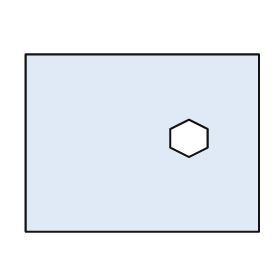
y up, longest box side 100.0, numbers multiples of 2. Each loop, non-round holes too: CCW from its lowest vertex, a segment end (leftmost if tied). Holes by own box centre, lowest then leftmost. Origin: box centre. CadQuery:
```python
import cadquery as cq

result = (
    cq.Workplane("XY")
    .moveTo(-50.0, -38.0)
    .lineTo(50.0, -38.0)
    .lineTo(50.0, 38.0)
    .lineTo(-50.0, 38.0)
    .close()
    .moveTo(20.0, -6.0)
    .lineTo(28.0, -2.0)
    .lineTo(28.0, 6.0)
    .lineTo(20.0, 10.0)
    .lineTo(12.0, 6.0)
    .lineTo(12.0, -2.0)
    .close()
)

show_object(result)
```